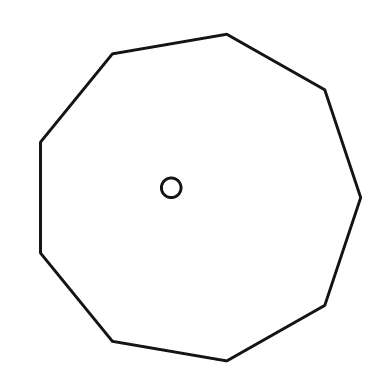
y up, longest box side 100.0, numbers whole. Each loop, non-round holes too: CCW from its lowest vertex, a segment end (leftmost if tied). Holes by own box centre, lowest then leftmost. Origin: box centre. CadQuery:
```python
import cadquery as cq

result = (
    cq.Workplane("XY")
    .moveTo(8.0, -50.0)
    .lineTo(38.0, -33.0)
    .lineTo(49.0, 0.0)
    .lineTo(38.0, 33.0)
    .lineTo(8.0, 50.0)
    .lineTo(-27.0, 44.0)
    .lineTo(-49.0, 17.0)
    .lineTo(-49.0, -17.0)
    .lineTo(-27.0, -44.0)
    .close()
    .moveTo(-9.0, 3.0)
    .circle(3.0)
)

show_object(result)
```